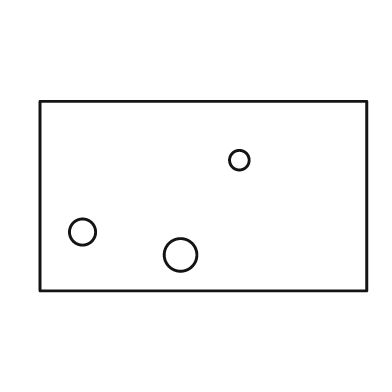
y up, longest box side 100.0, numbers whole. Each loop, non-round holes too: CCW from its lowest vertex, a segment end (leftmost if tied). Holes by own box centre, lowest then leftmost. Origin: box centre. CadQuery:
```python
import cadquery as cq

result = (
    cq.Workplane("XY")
    .moveTo(-50.0, -29.0)
    .lineTo(50.0, -29.0)
    .lineTo(50.0, 29.0)
    .lineTo(-50.0, 29.0)
    .close()
    .moveTo(-7.0, -18.0)
    .circle(5.0)
    .moveTo(-37.0, -11.0)
    .circle(4.0)
    .moveTo(11.0, 11.0)
    .circle(3.0)
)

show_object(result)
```